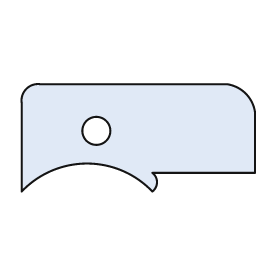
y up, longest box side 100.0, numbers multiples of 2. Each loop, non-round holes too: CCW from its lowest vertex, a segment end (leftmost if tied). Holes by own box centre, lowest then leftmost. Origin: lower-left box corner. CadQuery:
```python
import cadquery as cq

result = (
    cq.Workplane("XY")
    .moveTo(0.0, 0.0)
    .threePointArc((28.0, 12.0), (56.0, 0.0))
    .threePointArc((58.0, 4.0), (56.0, 8.0))
    .lineTo(100.0, 8.0)
    .lineTo(100.0, 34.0)
    .threePointArc((96.0, 42.0), (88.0, 46.0))
    .lineTo(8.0, 46.0)
    .threePointArc((2.0, 44.0), (0.0, 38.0))
    .close()
    .moveTo(32.0, 26.0)
    .circle(6.0)
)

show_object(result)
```